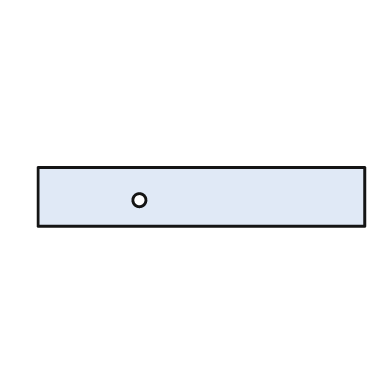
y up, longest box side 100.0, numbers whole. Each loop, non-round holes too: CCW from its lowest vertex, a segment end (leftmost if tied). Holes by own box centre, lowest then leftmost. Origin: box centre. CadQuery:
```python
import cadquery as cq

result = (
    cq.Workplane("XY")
    .moveTo(-50.0, -9.0)
    .lineTo(50.0, -9.0)
    .lineTo(50.0, 9.0)
    .lineTo(-50.0, 9.0)
    .close()
    .moveTo(-19.0, -1.0)
    .circle(2.0)
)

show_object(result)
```